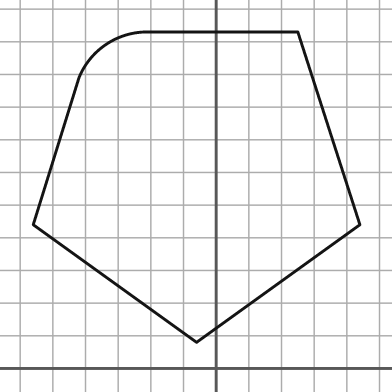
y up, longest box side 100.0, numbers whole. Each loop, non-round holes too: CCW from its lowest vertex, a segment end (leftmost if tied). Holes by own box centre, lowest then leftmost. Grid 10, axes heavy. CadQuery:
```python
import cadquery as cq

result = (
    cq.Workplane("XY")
    .moveTo(-6.0, 8.0)
    .lineTo(44.0, 44.0)
    .lineTo(25.0, 103.0)
    .lineTo(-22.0, 103.0)
    .threePointArc((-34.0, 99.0), (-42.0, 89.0))
    .lineTo(-56.0, 44.0)
    .close()
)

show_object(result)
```